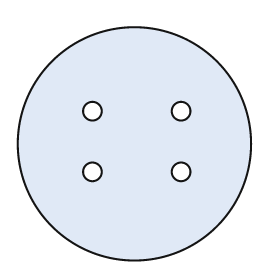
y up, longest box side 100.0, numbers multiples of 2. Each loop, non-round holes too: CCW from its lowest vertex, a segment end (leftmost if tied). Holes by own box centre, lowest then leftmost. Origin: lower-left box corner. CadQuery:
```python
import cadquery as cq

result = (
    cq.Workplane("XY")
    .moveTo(50.0, 50.0)
    .circle(50.0)
    .moveTo(32.0, 38.0)
    .circle(4.0)
    .moveTo(70.0, 38.0)
    .circle(4.0)
    .moveTo(32.0, 64.0)
    .circle(4.0)
    .moveTo(70.0, 64.0)
    .circle(4.0)
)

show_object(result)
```